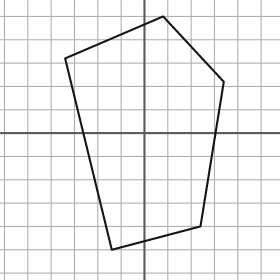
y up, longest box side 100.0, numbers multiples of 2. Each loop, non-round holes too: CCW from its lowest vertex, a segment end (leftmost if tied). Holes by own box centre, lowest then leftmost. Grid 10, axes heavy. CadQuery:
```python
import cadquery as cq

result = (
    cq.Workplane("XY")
    .moveTo(-14.0, -50.0)
    .lineTo(24.0, -40.0)
    .lineTo(34.0, 22.0)
    .lineTo(8.0, 50.0)
    .lineTo(-34.0, 32.0)
    .close()
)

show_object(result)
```